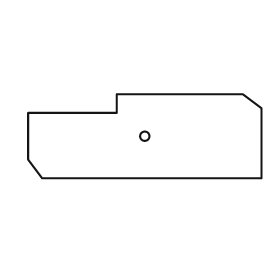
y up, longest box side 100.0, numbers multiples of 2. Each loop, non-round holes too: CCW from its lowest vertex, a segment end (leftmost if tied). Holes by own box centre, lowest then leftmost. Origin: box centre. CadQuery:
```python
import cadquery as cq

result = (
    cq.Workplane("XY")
    .moveTo(-44.0, -18.0)
    .lineTo(50.0, -18.0)
    .lineTo(50.0, 12.0)
    .lineTo(42.0, 18.0)
    .lineTo(-12.0, 18.0)
    .lineTo(-12.0, 10.0)
    .lineTo(-50.0, 10.0)
    .lineTo(-50.0, -10.0)
    .close()
    .moveTo(0.0, 0.0)
    .circle(2.0)
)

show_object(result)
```